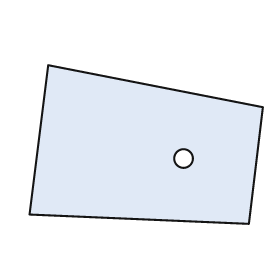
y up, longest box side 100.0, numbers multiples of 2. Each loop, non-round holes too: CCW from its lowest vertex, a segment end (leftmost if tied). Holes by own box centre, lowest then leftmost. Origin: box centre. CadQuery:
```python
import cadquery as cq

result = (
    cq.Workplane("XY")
    .moveTo(44.0, -34.0)
    .lineTo(50.0, 16.0)
    .lineTo(-42.0, 34.0)
    .lineTo(-50.0, -30.0)
    .close()
    .moveTo(16.0, -6.0)
    .circle(4.0)
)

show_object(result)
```